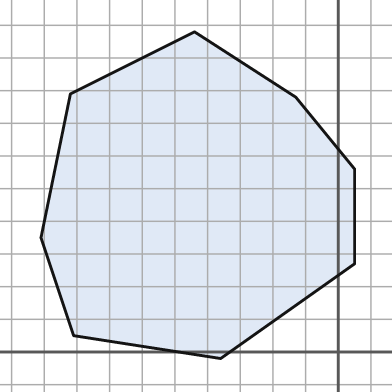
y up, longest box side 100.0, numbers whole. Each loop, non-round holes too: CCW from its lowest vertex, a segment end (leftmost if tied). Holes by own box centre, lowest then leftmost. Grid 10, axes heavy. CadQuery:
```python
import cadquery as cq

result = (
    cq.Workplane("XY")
    .moveTo(-36.0, -2.0)
    .lineTo(5.0, 27.0)
    .lineTo(5.0, 56.0)
    .lineTo(-13.0, 78.0)
    .lineTo(-44.0, 98.0)
    .lineTo(-82.0, 79.0)
    .lineTo(-91.0, 35.0)
    .lineTo(-81.0, 5.0)
    .close()
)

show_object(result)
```